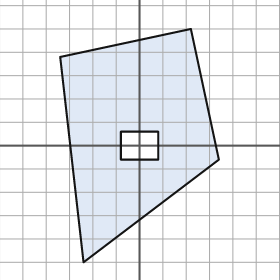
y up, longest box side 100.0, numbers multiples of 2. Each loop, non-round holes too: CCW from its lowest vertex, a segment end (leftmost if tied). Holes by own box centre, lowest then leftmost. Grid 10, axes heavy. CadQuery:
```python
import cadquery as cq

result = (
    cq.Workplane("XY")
    .moveTo(-24.0, -50.0)
    .lineTo(34.0, -6.0)
    .lineTo(22.0, 50.0)
    .lineTo(-34.0, 38.0)
    .close()
    .moveTo(-8.0, -6.0)
    .lineTo(8.0, -6.0)
    .lineTo(8.0, 6.0)
    .lineTo(-8.0, 6.0)
    .close()
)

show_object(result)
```